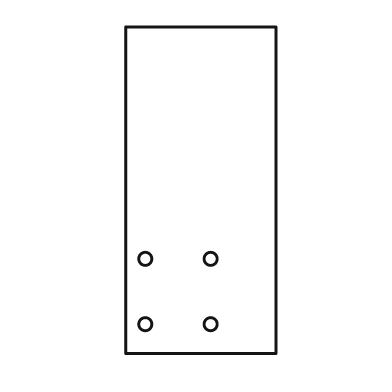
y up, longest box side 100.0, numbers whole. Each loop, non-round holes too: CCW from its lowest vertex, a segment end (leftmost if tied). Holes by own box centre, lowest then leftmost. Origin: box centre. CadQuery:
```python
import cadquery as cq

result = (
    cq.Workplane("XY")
    .moveTo(-23.0, -50.0)
    .lineTo(23.0, -50.0)
    .lineTo(23.0, 50.0)
    .lineTo(-23.0, 50.0)
    .close()
    .moveTo(-17.0, -41.0)
    .circle(2.0)
    .moveTo(3.0, -41.0)
    .circle(2.0)
    .moveTo(-17.0, -21.0)
    .circle(2.0)
    .moveTo(3.0, -21.0)
    .circle(2.0)
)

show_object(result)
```